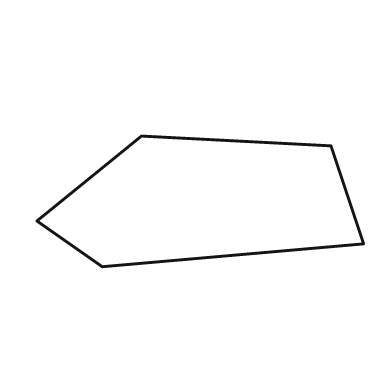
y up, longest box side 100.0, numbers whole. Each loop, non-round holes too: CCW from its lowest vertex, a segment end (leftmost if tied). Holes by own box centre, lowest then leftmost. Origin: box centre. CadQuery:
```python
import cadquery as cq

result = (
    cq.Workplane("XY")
    .moveTo(-30.0, -20.0)
    .lineTo(50.0, -13.0)
    .lineTo(40.0, 17.0)
    .lineTo(-18.0, 20.0)
    .lineTo(-50.0, -6.0)
    .close()
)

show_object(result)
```